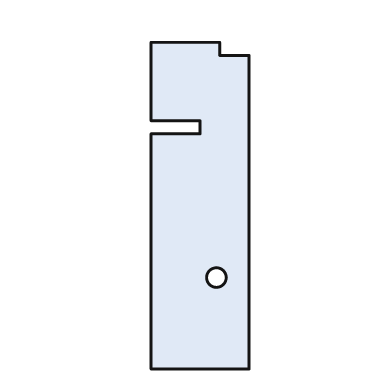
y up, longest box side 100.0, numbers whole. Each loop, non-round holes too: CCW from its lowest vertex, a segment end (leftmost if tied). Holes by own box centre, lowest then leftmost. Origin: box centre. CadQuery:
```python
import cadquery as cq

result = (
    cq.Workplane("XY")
    .moveTo(-15.0, -50.0)
    .lineTo(15.0, -50.0)
    .lineTo(15.0, 46.0)
    .lineTo(6.0, 46.0)
    .lineTo(6.0, 50.0)
    .lineTo(-15.0, 50.0)
    .lineTo(-15.0, 26.0)
    .lineTo(0.0, 26.0)
    .lineTo(0.0, 22.0)
    .lineTo(-15.0, 22.0)
    .close()
    .moveTo(5.0, -22.0)
    .circle(3.0)
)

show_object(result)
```